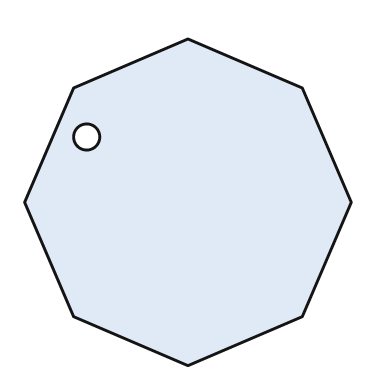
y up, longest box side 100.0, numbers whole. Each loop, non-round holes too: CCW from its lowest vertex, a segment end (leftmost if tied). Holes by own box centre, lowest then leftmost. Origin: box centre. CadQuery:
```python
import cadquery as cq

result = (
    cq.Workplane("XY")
    .moveTo(0.0, -50.0)
    .lineTo(35.0, -35.0)
    .lineTo(50.0, 0.0)
    .lineTo(35.0, 35.0)
    .lineTo(0.0, 50.0)
    .lineTo(-35.0, 35.0)
    .lineTo(-50.0, 0.0)
    .lineTo(-35.0, -35.0)
    .close()
    .moveTo(-31.0, 20.0)
    .circle(4.0)
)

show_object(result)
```